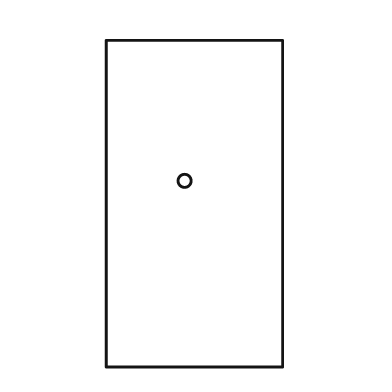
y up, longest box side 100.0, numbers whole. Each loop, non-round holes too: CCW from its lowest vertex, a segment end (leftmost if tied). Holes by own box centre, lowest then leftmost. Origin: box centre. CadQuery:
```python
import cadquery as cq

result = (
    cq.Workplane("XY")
    .moveTo(-27.0, -50.0)
    .lineTo(27.0, -50.0)
    .lineTo(27.0, 50.0)
    .lineTo(-27.0, 50.0)
    .close()
    .moveTo(-3.0, 7.0)
    .circle(2.0)
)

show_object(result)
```